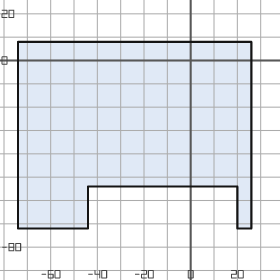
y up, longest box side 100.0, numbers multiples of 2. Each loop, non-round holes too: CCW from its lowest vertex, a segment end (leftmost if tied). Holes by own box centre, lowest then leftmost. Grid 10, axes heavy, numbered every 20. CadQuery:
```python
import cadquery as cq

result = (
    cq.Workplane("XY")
    .moveTo(-74.0, -72.0)
    .lineTo(-44.0, -72.0)
    .lineTo(-44.0, -54.0)
    .lineTo(20.0, -54.0)
    .lineTo(20.0, -72.0)
    .lineTo(26.0, -72.0)
    .lineTo(26.0, 8.0)
    .lineTo(-74.0, 8.0)
    .close()
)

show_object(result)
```